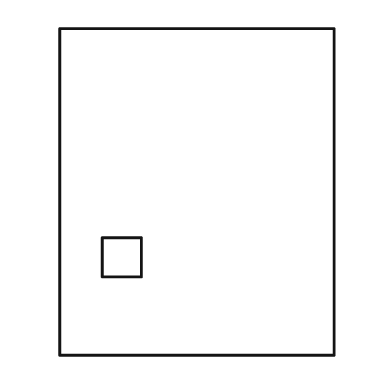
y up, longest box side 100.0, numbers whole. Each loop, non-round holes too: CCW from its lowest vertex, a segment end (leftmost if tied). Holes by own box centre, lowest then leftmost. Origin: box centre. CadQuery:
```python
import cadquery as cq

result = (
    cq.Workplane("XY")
    .moveTo(-42.0, -50.0)
    .lineTo(42.0, -50.0)
    .lineTo(42.0, 50.0)
    .lineTo(-42.0, 50.0)
    .close()
    .moveTo(-29.0, -26.0)
    .lineTo(-17.0, -26.0)
    .lineTo(-17.0, -14.0)
    .lineTo(-29.0, -14.0)
    .close()
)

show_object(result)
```